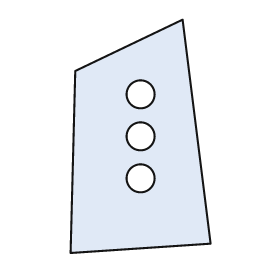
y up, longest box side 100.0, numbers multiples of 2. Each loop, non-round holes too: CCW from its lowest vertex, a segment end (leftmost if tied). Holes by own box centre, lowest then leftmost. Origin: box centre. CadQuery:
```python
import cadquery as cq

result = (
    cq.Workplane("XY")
    .moveTo(-30.0, -50.0)
    .lineTo(30.0, -46.0)
    .lineTo(18.0, 50.0)
    .lineTo(-28.0, 28.0)
    .close()
    .moveTo(0.0, -18.0)
    .circle(6.0)
    .moveTo(0.0, 0.0)
    .circle(6.0)
    .moveTo(0.0, 18.0)
    .circle(6.0)
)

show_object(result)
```